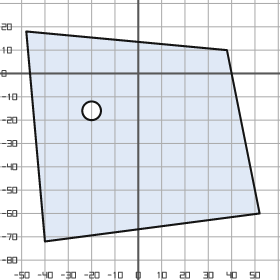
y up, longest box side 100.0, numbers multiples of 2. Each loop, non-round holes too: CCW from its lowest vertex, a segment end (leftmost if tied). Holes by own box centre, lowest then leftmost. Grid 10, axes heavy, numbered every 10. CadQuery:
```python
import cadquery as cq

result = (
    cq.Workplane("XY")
    .moveTo(-40.0, -72.0)
    .lineTo(52.0, -60.0)
    .lineTo(38.0, 10.0)
    .lineTo(-48.0, 18.0)
    .close()
    .moveTo(-20.0, -16.0)
    .circle(4.0)
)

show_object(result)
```